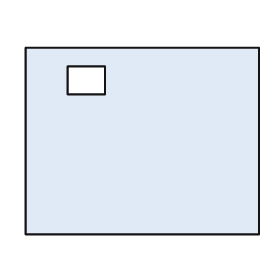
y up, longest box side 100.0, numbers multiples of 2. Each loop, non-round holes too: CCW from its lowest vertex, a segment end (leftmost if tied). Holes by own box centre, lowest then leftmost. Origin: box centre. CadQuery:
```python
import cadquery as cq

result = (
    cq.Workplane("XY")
    .moveTo(-50.0, -40.0)
    .lineTo(50.0, -40.0)
    .lineTo(50.0, 40.0)
    .lineTo(-50.0, 40.0)
    .close()
    .moveTo(-32.0, 20.0)
    .lineTo(-16.0, 20.0)
    .lineTo(-16.0, 32.0)
    .lineTo(-32.0, 32.0)
    .close()
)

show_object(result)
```